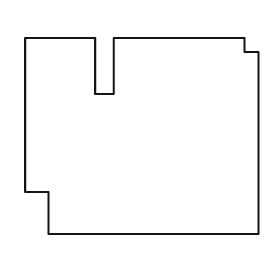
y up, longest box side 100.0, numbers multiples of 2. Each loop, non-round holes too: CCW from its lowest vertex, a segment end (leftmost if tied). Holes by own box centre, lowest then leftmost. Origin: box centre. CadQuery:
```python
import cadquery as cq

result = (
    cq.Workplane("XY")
    .moveTo(-40.0, -42.0)
    .lineTo(50.0, -42.0)
    .lineTo(50.0, 36.0)
    .lineTo(44.0, 36.0)
    .lineTo(44.0, 42.0)
    .lineTo(-12.0, 42.0)
    .lineTo(-12.0, 18.0)
    .lineTo(-20.0, 18.0)
    .lineTo(-20.0, 42.0)
    .lineTo(-50.0, 42.0)
    .lineTo(-50.0, -24.0)
    .lineTo(-40.0, -24.0)
    .close()
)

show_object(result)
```